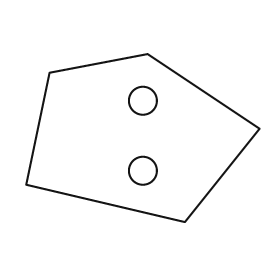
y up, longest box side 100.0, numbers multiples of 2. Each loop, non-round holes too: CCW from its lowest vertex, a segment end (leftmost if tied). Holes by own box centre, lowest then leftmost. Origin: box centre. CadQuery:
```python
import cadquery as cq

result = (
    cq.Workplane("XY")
    .moveTo(18.0, -36.0)
    .lineTo(50.0, 4.0)
    .lineTo(2.0, 36.0)
    .lineTo(-40.0, 28.0)
    .lineTo(-50.0, -20.0)
    .close()
    .moveTo(0.0, -14.0)
    .circle(6.0)
    .moveTo(0.0, 16.0)
    .circle(6.0)
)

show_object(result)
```